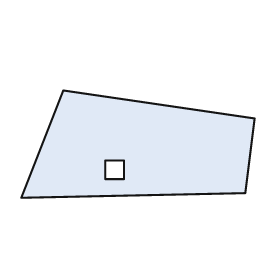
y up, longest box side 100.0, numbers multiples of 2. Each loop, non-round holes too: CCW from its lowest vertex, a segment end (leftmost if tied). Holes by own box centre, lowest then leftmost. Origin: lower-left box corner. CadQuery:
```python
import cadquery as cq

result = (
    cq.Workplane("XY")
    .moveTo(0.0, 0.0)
    .lineTo(96.0, 2.0)
    .lineTo(100.0, 34.0)
    .lineTo(18.0, 46.0)
    .close()
    .moveTo(36.0, 8.0)
    .lineTo(44.0, 8.0)
    .lineTo(44.0, 16.0)
    .lineTo(36.0, 16.0)
    .close()
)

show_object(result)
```